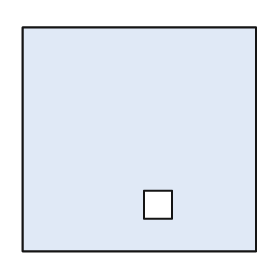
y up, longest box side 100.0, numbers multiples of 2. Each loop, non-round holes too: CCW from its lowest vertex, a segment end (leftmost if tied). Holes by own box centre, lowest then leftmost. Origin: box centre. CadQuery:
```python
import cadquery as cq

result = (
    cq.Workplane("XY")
    .moveTo(-50.0, -48.0)
    .lineTo(50.0, -48.0)
    .lineTo(50.0, 48.0)
    .lineTo(-50.0, 48.0)
    .close()
    .moveTo(2.0, -34.0)
    .lineTo(14.0, -34.0)
    .lineTo(14.0, -22.0)
    .lineTo(2.0, -22.0)
    .close()
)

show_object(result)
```